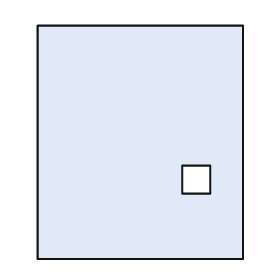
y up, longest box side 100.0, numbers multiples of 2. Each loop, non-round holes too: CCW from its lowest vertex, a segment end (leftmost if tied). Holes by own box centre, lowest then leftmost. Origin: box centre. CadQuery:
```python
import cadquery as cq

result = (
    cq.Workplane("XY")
    .moveTo(-44.0, -50.0)
    .lineTo(44.0, -50.0)
    .lineTo(44.0, 50.0)
    .lineTo(-44.0, 50.0)
    .close()
    .moveTo(18.0, -22.0)
    .lineTo(30.0, -22.0)
    .lineTo(30.0, -10.0)
    .lineTo(18.0, -10.0)
    .close()
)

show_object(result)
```